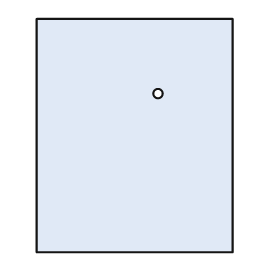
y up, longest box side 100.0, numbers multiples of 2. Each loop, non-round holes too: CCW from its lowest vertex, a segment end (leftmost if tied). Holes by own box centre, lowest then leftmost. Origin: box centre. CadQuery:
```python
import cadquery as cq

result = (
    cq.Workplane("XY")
    .moveTo(-42.0, -50.0)
    .lineTo(42.0, -50.0)
    .lineTo(42.0, 50.0)
    .lineTo(-42.0, 50.0)
    .close()
    .moveTo(10.0, 18.0)
    .circle(2.0)
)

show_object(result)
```